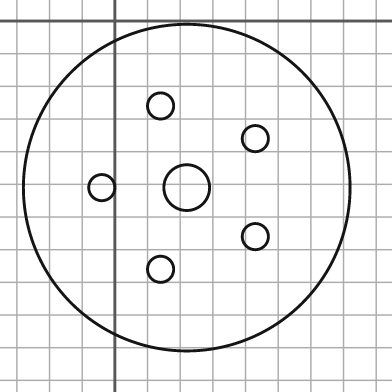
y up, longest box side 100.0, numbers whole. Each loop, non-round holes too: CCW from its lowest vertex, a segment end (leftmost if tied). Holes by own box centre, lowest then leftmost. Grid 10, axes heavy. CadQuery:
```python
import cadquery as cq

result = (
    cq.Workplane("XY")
    .moveTo(22.0, -51.0)
    .circle(50.0)
    .moveTo(14.0, -76.0)
    .circle(4.0)
    .moveTo(43.0, -66.0)
    .circle(4.0)
    .moveTo(-4.0, -51.0)
    .circle(4.0)
    .moveTo(22.0, -51.0)
    .circle(7.0)
    .moveTo(43.0, -36.0)
    .circle(4.0)
    .moveTo(14.0, -26.0)
    .circle(4.0)
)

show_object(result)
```